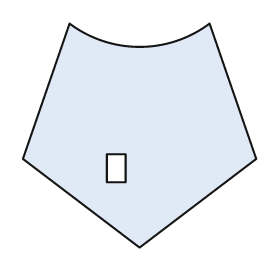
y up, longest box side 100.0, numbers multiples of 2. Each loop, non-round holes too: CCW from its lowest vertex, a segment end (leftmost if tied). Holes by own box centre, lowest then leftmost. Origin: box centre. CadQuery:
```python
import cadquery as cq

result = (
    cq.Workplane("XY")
    .moveTo(0.0, -48.0)
    .lineTo(50.0, -10.0)
    .lineTo(30.0, 48.0)
    .threePointArc((0.0, 38.0), (-30.0, 48.0))
    .lineTo(-50.0, -10.0)
    .close()
    .moveTo(-14.0, -20.0)
    .lineTo(-6.0, -20.0)
    .lineTo(-6.0, -8.0)
    .lineTo(-14.0, -8.0)
    .close()
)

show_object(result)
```